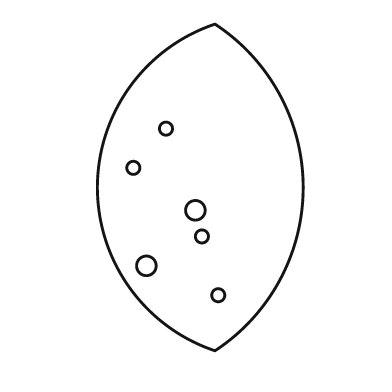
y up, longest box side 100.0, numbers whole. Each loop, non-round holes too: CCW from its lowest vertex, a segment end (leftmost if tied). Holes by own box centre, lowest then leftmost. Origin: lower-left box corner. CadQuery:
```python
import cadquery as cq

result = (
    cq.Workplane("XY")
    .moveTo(36.0, 0.0)
    .threePointArc((63.0, 50.0), (36.0, 100.0))
    .threePointArc((0.0, 50.0), (36.0, 0.0))
    .close()
    .moveTo(37.0, 17.0)
    .circle(2.0)
    .moveTo(15.0, 26.0)
    .circle(3.0)
    .moveTo(32.0, 35.0)
    .circle(2.0)
    .moveTo(30.0, 43.0)
    .circle(3.0)
    .moveTo(11.0, 56.0)
    .circle(2.0)
    .moveTo(21.0, 68.0)
    .circle(2.0)
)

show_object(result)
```